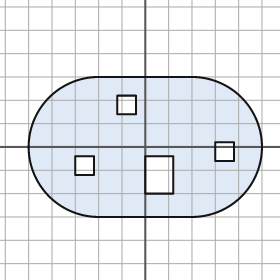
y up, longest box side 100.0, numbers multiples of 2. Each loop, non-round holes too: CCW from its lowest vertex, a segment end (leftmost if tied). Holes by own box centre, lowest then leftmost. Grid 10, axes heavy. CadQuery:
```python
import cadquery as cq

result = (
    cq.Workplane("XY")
    .moveTo(-20.0, -30.0)
    .lineTo(20.0, -30.0)
    .threePointArc((50.0, 0.0), (20.0, 30.0))
    .lineTo(-20.0, 30.0)
    .threePointArc((-50.0, 0.0), (-20.0, -30.0))
    .close()
    .moveTo(0.0, -20.0)
    .lineTo(12.0, -20.0)
    .lineTo(12.0, -4.0)
    .lineTo(0.0, -4.0)
    .close()
    .moveTo(-30.0, -12.0)
    .lineTo(-22.0, -12.0)
    .lineTo(-22.0, -4.0)
    .lineTo(-30.0, -4.0)
    .close()
    .moveTo(30.0, -6.0)
    .lineTo(38.0, -6.0)
    .lineTo(38.0, 2.0)
    .lineTo(30.0, 2.0)
    .close()
    .moveTo(-12.0, 14.0)
    .lineTo(-4.0, 14.0)
    .lineTo(-4.0, 22.0)
    .lineTo(-12.0, 22.0)
    .close()
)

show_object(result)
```